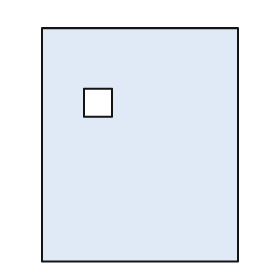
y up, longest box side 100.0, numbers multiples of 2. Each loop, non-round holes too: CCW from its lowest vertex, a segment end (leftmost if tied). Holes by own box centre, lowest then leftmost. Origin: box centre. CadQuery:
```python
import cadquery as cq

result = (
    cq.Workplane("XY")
    .moveTo(-42.0, -50.0)
    .lineTo(42.0, -50.0)
    .lineTo(42.0, 50.0)
    .lineTo(-42.0, 50.0)
    .close()
    .moveTo(-24.0, 12.0)
    .lineTo(-12.0, 12.0)
    .lineTo(-12.0, 24.0)
    .lineTo(-24.0, 24.0)
    .close()
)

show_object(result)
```